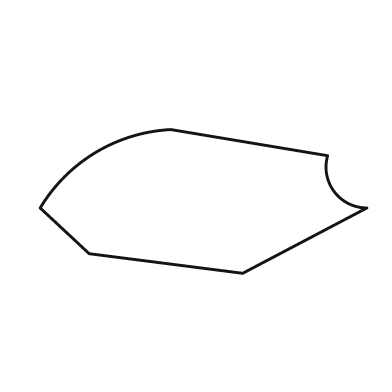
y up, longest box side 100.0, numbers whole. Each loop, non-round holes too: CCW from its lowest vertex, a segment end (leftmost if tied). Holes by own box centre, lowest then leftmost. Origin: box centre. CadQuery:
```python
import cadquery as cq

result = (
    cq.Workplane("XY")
    .moveTo(12.0, -22.0)
    .lineTo(50.0, -2.0)
    .threePointArc((40.0, 3.0), (38.0, 14.0))
    .lineTo(-10.0, 22.0)
    .threePointArc((-33.0, 15.0), (-50.0, -2.0))
    .lineTo(-35.0, -16.0)
    .close()
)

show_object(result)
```